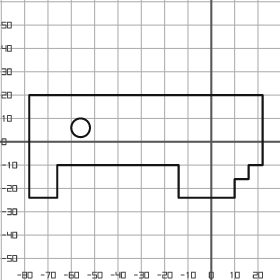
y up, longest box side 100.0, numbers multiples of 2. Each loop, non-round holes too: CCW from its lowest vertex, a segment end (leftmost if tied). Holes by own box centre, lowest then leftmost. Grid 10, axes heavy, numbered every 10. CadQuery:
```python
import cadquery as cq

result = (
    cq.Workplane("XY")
    .moveTo(-78.0, -24.0)
    .lineTo(-66.0, -24.0)
    .lineTo(-66.0, -10.0)
    .lineTo(-14.0, -10.0)
    .lineTo(-14.0, -24.0)
    .lineTo(10.0, -24.0)
    .lineTo(10.0, -16.0)
    .lineTo(16.0, -16.0)
    .lineTo(16.0, -10.0)
    .lineTo(22.0, -10.0)
    .lineTo(22.0, 20.0)
    .lineTo(-78.0, 20.0)
    .close()
    .moveTo(-56.0, 6.0)
    .circle(4.0)
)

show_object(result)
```